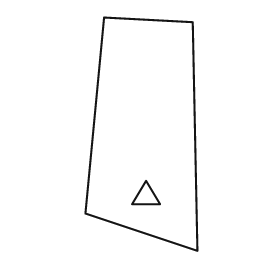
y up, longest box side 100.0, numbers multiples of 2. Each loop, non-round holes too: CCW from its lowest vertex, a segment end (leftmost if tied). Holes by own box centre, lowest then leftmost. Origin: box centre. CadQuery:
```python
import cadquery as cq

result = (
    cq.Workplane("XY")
    .moveTo(24.0, -50.0)
    .lineTo(22.0, 48.0)
    .lineTo(-16.0, 50.0)
    .lineTo(-24.0, -34.0)
    .close()
    .moveTo(-4.0, -30.0)
    .lineTo(8.0, -30.0)
    .lineTo(2.0, -20.0)
    .close()
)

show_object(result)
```